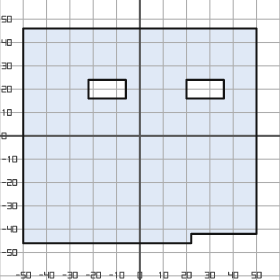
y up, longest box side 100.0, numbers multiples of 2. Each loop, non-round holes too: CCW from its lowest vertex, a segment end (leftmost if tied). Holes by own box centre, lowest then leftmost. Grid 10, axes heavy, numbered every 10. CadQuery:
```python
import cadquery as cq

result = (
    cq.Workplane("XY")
    .moveTo(-50.0, -46.0)
    .lineTo(22.0, -46.0)
    .lineTo(22.0, -42.0)
    .lineTo(50.0, -42.0)
    .lineTo(50.0, 46.0)
    .lineTo(-50.0, 46.0)
    .close()
    .moveTo(-22.0, 16.0)
    .lineTo(-6.0, 16.0)
    .lineTo(-6.0, 24.0)
    .lineTo(-22.0, 24.0)
    .close()
    .moveTo(20.0, 16.0)
    .lineTo(36.0, 16.0)
    .lineTo(36.0, 24.0)
    .lineTo(20.0, 24.0)
    .close()
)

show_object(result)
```